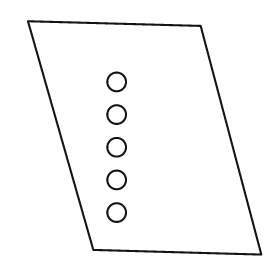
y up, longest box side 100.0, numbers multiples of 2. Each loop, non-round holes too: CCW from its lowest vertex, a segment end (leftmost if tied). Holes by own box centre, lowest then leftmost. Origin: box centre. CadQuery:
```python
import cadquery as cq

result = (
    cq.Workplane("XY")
    .moveTo(50.0, -50.0)
    .lineTo(24.0, 48.0)
    .lineTo(-50.0, 50.0)
    .lineTo(-22.0, -48.0)
    .close()
    .moveTo(-12.0, -32.0)
    .circle(4.0)
    .moveTo(-12.0, -18.0)
    .circle(4.0)
    .moveTo(-12.0, -4.0)
    .circle(4.0)
    .moveTo(-12.0, 10.0)
    .circle(4.0)
    .moveTo(-12.0, 24.0)
    .circle(4.0)
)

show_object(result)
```